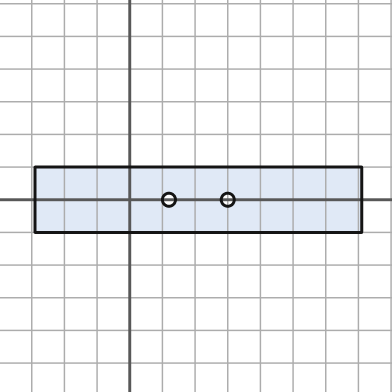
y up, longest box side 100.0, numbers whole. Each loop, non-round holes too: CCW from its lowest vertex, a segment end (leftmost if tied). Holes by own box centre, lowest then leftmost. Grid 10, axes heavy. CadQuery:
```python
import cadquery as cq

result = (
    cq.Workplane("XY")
    .moveTo(-29.0, -10.0)
    .lineTo(71.0, -10.0)
    .lineTo(71.0, 10.0)
    .lineTo(-29.0, 10.0)
    .close()
    .moveTo(12.0, 0.0)
    .circle(2.0)
    .moveTo(30.0, 0.0)
    .circle(2.0)
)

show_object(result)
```